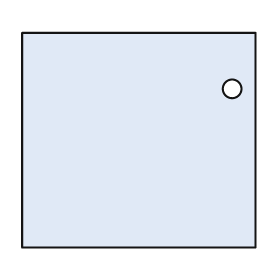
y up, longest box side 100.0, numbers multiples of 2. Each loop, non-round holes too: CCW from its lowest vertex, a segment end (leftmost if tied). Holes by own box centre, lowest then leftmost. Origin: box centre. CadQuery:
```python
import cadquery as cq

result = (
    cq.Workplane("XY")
    .moveTo(-50.0, -46.0)
    .lineTo(50.0, -46.0)
    .lineTo(50.0, 46.0)
    .lineTo(-50.0, 46.0)
    .close()
    .moveTo(40.0, 22.0)
    .circle(4.0)
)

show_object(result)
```